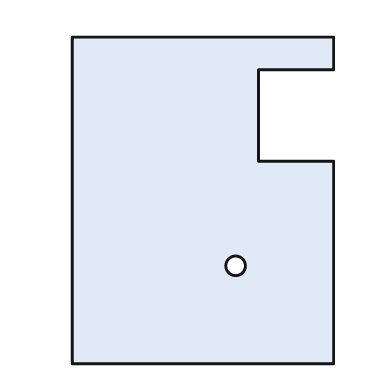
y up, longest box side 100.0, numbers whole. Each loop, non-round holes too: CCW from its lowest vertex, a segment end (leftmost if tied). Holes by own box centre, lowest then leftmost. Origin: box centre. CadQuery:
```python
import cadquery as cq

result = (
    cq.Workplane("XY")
    .moveTo(-40.0, -50.0)
    .lineTo(40.0, -50.0)
    .lineTo(40.0, 12.0)
    .lineTo(17.0, 12.0)
    .lineTo(17.0, 40.0)
    .lineTo(40.0, 40.0)
    .lineTo(40.0, 50.0)
    .lineTo(-40.0, 50.0)
    .close()
    .moveTo(10.0, -20.0)
    .circle(3.0)
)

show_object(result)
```